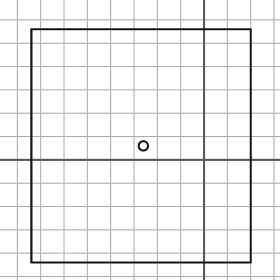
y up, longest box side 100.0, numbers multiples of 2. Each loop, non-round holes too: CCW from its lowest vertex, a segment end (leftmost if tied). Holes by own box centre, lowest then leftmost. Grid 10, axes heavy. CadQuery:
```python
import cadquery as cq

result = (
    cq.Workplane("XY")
    .moveTo(-74.0, -44.0)
    .lineTo(20.0, -44.0)
    .lineTo(20.0, 56.0)
    .lineTo(-74.0, 56.0)
    .close()
    .moveTo(-26.0, 6.0)
    .circle(2.0)
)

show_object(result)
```